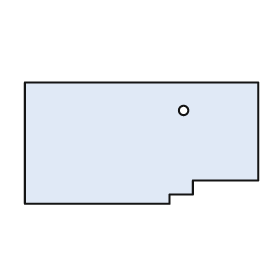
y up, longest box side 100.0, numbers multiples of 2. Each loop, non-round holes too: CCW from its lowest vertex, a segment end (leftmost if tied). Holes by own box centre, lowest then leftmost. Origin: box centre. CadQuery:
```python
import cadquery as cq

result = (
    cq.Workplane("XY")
    .moveTo(-50.0, -26.0)
    .lineTo(12.0, -26.0)
    .lineTo(12.0, -22.0)
    .lineTo(22.0, -22.0)
    .lineTo(22.0, -16.0)
    .lineTo(50.0, -16.0)
    .lineTo(50.0, 26.0)
    .lineTo(-50.0, 26.0)
    .close()
    .moveTo(18.0, 14.0)
    .circle(2.0)
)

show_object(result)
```